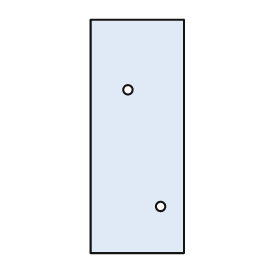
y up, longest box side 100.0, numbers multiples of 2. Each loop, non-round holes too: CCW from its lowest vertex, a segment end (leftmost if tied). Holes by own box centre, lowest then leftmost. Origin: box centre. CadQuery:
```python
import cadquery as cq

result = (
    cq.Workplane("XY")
    .moveTo(-20.0, -50.0)
    .lineTo(20.0, -50.0)
    .lineTo(20.0, 50.0)
    .lineTo(-20.0, 50.0)
    .close()
    .moveTo(10.0, -30.0)
    .circle(2.0)
    .moveTo(-4.0, 20.0)
    .circle(2.0)
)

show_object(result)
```